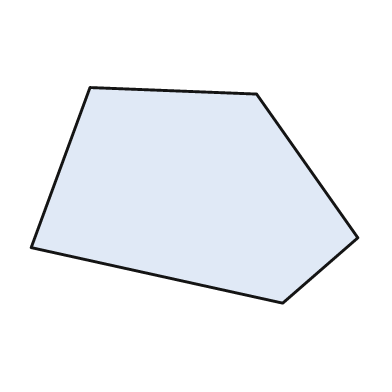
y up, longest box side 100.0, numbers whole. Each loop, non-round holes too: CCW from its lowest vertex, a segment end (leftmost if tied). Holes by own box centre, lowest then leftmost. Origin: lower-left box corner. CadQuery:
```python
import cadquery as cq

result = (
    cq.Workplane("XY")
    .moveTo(77.0, 0.0)
    .lineTo(100.0, 20.0)
    .lineTo(69.0, 64.0)
    .lineTo(18.0, 66.0)
    .lineTo(0.0, 17.0)
    .close()
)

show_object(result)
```